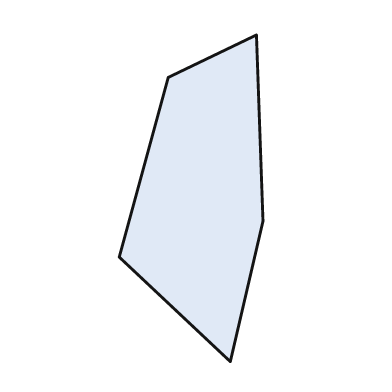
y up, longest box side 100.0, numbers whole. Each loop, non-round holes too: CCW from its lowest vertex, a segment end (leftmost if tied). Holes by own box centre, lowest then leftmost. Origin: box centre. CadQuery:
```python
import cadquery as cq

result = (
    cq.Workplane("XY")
    .moveTo(12.0, -50.0)
    .lineTo(22.0, -7.0)
    .lineTo(20.0, 50.0)
    .lineTo(-7.0, 37.0)
    .lineTo(-22.0, -18.0)
    .close()
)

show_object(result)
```